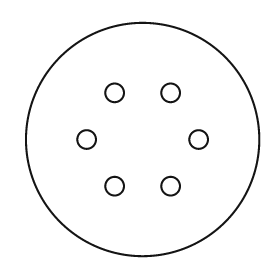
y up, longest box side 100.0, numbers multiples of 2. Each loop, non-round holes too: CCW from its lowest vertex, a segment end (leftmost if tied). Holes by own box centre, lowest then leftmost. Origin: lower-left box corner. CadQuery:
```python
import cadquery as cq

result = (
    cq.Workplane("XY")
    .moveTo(50.0, 50.0)
    .circle(50.0)
    .moveTo(38.0, 30.0)
    .circle(4.0)
    .moveTo(62.0, 30.0)
    .circle(4.0)
    .moveTo(26.0, 50.0)
    .circle(4.0)
    .moveTo(74.0, 50.0)
    .circle(4.0)
    .moveTo(38.0, 70.0)
    .circle(4.0)
    .moveTo(62.0, 70.0)
    .circle(4.0)
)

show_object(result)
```